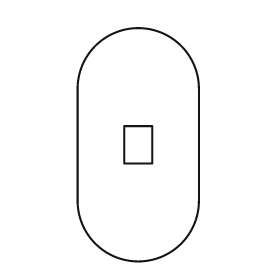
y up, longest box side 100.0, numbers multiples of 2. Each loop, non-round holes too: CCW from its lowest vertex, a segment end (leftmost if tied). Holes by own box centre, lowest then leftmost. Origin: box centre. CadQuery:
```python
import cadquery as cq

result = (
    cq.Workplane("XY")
    .moveTo(-26.0, -24.0)
    .threePointArc((0.0, -50.0), (26.0, -24.0))
    .lineTo(26.0, 24.0)
    .threePointArc((0.0, 50.0), (-26.0, 24.0))
    .close()
    .moveTo(-6.0, -8.0)
    .lineTo(6.0, -8.0)
    .lineTo(6.0, 8.0)
    .lineTo(-6.0, 8.0)
    .close()
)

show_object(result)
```